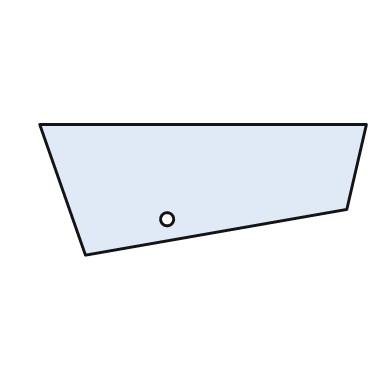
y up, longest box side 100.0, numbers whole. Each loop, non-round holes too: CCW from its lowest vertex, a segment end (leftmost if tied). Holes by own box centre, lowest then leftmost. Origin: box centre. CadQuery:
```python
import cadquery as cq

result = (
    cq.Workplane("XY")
    .moveTo(-36.0, -20.0)
    .lineTo(44.0, -6.0)
    .lineTo(50.0, 20.0)
    .lineTo(-50.0, 20.0)
    .close()
    .moveTo(-11.0, -9.0)
    .circle(2.0)
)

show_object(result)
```